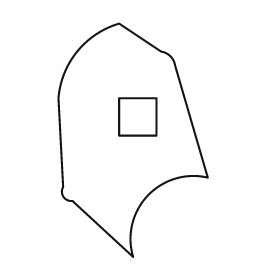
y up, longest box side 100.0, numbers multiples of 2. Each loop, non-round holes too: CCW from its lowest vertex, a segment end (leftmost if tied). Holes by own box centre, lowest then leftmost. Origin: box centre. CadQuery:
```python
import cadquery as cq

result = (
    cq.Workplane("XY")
    .moveTo(0.0, -50.0)
    .threePointArc((6.0, -24.0), (32.0, -16.0))
    .lineTo(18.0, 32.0)
    .threePointArc((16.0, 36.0), (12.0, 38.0))
    .lineTo(-6.0, 50.0)
    .threePointArc((-24.0, 38.0), (-32.0, 18.0))
    .lineTo(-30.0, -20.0)
    .threePointArc((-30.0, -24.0), (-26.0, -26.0))
    .close()
    .moveTo(-6.0, 2.0)
    .lineTo(10.0, 2.0)
    .lineTo(10.0, 18.0)
    .lineTo(-6.0, 18.0)
    .close()
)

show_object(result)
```